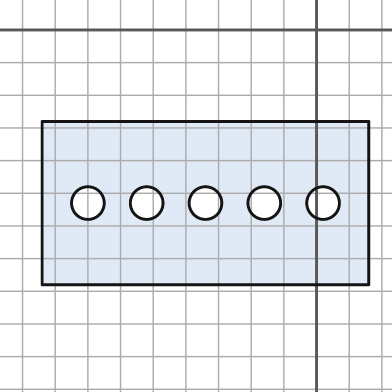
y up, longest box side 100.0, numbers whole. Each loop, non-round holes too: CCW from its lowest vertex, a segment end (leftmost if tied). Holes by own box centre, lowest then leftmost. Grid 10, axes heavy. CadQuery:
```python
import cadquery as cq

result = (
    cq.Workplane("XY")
    .moveTo(-84.0, -78.0)
    .lineTo(16.0, -78.0)
    .lineTo(16.0, -28.0)
    .lineTo(-84.0, -28.0)
    .close()
    .moveTo(-70.0, -53.0)
    .circle(5.0)
    .moveTo(-52.0, -53.0)
    .circle(5.0)
    .moveTo(-34.0, -53.0)
    .circle(5.0)
    .moveTo(-16.0, -53.0)
    .circle(5.0)
    .moveTo(2.0, -53.0)
    .circle(5.0)
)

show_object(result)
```